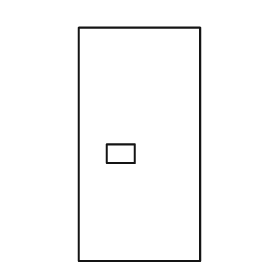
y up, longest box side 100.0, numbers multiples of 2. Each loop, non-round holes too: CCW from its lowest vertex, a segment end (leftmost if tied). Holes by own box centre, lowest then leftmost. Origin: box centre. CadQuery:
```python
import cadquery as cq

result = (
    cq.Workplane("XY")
    .moveTo(-26.0, -50.0)
    .lineTo(26.0, -50.0)
    .lineTo(26.0, 50.0)
    .lineTo(-26.0, 50.0)
    .close()
    .moveTo(-14.0, -8.0)
    .lineTo(-2.0, -8.0)
    .lineTo(-2.0, 0.0)
    .lineTo(-14.0, 0.0)
    .close()
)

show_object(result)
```